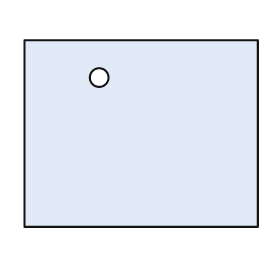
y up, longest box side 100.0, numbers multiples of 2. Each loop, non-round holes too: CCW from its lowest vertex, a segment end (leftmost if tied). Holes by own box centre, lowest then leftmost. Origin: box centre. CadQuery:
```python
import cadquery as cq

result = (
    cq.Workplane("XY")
    .moveTo(-50.0, -40.0)
    .lineTo(50.0, -40.0)
    .lineTo(50.0, 40.0)
    .lineTo(-50.0, 40.0)
    .close()
    .moveTo(-18.0, 24.0)
    .circle(4.0)
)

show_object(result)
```